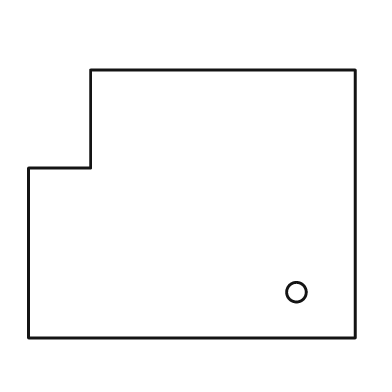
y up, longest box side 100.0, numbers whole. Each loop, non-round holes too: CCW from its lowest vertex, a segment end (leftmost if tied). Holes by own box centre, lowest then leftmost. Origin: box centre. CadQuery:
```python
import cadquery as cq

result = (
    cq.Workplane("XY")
    .moveTo(-50.0, -41.0)
    .lineTo(50.0, -41.0)
    .lineTo(50.0, 41.0)
    .lineTo(-31.0, 41.0)
    .lineTo(-31.0, 11.0)
    .lineTo(-50.0, 11.0)
    .close()
    .moveTo(32.0, -27.0)
    .circle(3.0)
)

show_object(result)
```